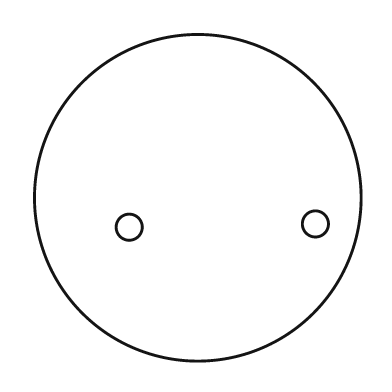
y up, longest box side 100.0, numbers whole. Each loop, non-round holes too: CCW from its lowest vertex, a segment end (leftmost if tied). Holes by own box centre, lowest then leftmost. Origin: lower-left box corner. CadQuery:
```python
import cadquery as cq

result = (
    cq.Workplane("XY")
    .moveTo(50.0, 50.0)
    .circle(50.0)
    .moveTo(29.0, 41.0)
    .circle(4.0)
    .moveTo(86.0, 42.0)
    .circle(4.0)
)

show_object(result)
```